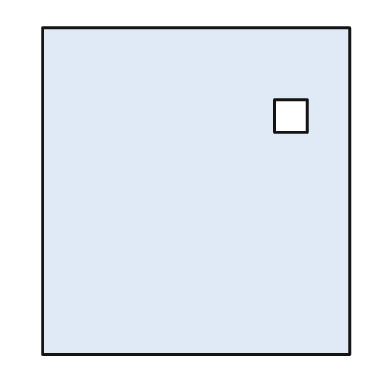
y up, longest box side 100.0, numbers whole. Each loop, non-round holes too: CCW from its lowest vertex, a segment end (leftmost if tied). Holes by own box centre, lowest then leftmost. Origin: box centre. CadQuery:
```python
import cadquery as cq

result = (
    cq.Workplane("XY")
    .moveTo(-47.0, -50.0)
    .lineTo(47.0, -50.0)
    .lineTo(47.0, 50.0)
    .lineTo(-47.0, 50.0)
    .close()
    .moveTo(24.0, 18.0)
    .lineTo(34.0, 18.0)
    .lineTo(34.0, 28.0)
    .lineTo(24.0, 28.0)
    .close()
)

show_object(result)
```